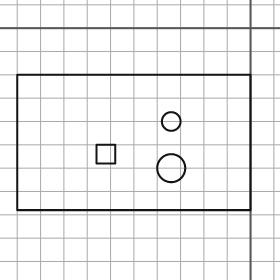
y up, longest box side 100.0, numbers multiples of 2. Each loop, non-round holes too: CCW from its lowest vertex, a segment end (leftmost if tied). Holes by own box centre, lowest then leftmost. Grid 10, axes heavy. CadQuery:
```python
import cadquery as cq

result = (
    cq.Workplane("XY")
    .moveTo(-100.0, -78.0)
    .lineTo(0.0, -78.0)
    .lineTo(0.0, -20.0)
    .lineTo(-100.0, -20.0)
    .close()
    .moveTo(-34.0, -60.0)
    .circle(6.0)
    .moveTo(-66.0, -58.0)
    .lineTo(-58.0, -58.0)
    .lineTo(-58.0, -50.0)
    .lineTo(-66.0, -50.0)
    .close()
    .moveTo(-34.0, -40.0)
    .circle(4.0)
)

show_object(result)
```